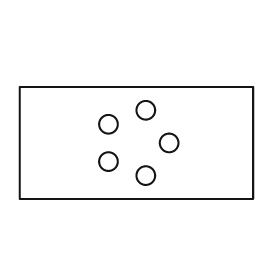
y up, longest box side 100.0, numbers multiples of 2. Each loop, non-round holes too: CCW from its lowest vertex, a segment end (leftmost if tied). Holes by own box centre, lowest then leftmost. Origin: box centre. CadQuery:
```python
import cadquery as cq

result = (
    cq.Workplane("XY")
    .moveTo(-50.0, -24.0)
    .lineTo(50.0, -24.0)
    .lineTo(50.0, 24.0)
    .lineTo(-50.0, 24.0)
    .close()
    .moveTo(4.0, -14.0)
    .circle(4.0)
    .moveTo(-12.0, -8.0)
    .circle(4.0)
    .moveTo(14.0, 0.0)
    .circle(4.0)
    .moveTo(-12.0, 8.0)
    .circle(4.0)
    .moveTo(4.0, 14.0)
    .circle(4.0)
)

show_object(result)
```